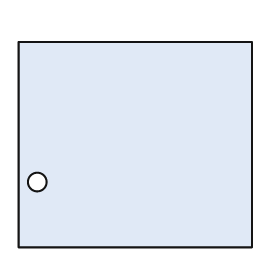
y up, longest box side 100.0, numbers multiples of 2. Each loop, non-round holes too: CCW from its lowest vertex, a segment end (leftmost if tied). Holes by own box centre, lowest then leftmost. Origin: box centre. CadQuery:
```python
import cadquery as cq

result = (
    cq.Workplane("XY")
    .moveTo(-50.0, -44.0)
    .lineTo(50.0, -44.0)
    .lineTo(50.0, 44.0)
    .lineTo(-50.0, 44.0)
    .close()
    .moveTo(-42.0, -16.0)
    .circle(4.0)
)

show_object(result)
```